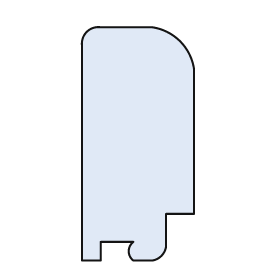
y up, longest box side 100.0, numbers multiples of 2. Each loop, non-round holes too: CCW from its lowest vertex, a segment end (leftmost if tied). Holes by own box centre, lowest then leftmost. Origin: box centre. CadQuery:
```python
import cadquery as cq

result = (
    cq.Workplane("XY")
    .moveTo(-24.0, -50.0)
    .lineTo(-16.0, -50.0)
    .lineTo(-16.0, -42.0)
    .lineTo(-2.0, -42.0)
    .threePointArc((-4.0, -46.0), (-2.0, -50.0))
    .lineTo(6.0, -50.0)
    .threePointArc((10.0, -48.0), (12.0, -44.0))
    .lineTo(12.0, -30.0)
    .lineTo(24.0, -30.0)
    .lineTo(24.0, 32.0)
    .threePointArc((18.0, 44.0), (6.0, 50.0))
    .lineTo(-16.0, 50.0)
    .threePointArc((-22.0, 48.0), (-24.0, 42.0))
    .close()
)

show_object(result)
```